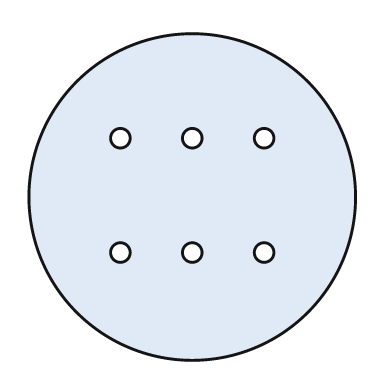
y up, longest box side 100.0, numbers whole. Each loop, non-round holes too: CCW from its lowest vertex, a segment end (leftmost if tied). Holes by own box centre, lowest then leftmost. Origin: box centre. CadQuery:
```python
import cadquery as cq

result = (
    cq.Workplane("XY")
    .moveTo(0.0, 0.0)
    .circle(50.0)
    .moveTo(-22.0, -17.0)
    .circle(3.0)
    .moveTo(0.0, -17.0)
    .circle(3.0)
    .moveTo(22.0, -17.0)
    .circle(3.0)
    .moveTo(-22.0, 18.0)
    .circle(3.0)
    .moveTo(0.0, 18.0)
    .circle(3.0)
    .moveTo(22.0, 18.0)
    .circle(3.0)
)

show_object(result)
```